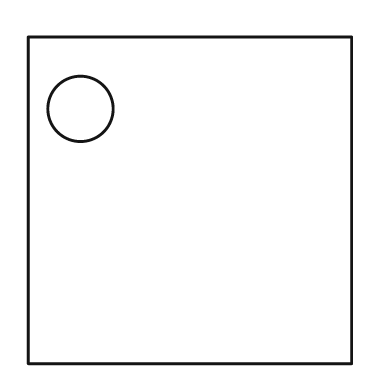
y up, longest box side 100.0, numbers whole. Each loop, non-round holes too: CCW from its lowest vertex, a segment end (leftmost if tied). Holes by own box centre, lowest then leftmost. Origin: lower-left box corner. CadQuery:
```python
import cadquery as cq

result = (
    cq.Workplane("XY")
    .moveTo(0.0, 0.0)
    .lineTo(99.0, 0.0)
    .lineTo(99.0, 100.0)
    .lineTo(0.0, 100.0)
    .close()
    .moveTo(16.0, 78.0)
    .circle(10.0)
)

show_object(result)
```